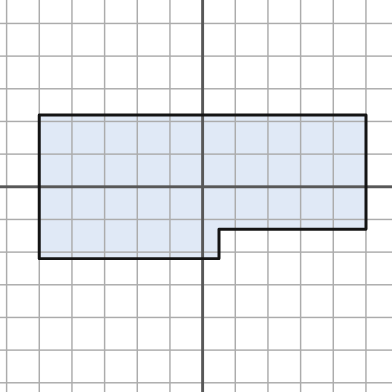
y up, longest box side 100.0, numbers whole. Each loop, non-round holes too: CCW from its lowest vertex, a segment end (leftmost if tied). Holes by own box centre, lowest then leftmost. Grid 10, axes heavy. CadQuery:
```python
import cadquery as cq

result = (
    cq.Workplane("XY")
    .moveTo(-50.0, -22.0)
    .lineTo(5.0, -22.0)
    .lineTo(5.0, -13.0)
    .lineTo(50.0, -13.0)
    .lineTo(50.0, 22.0)
    .lineTo(-50.0, 22.0)
    .close()
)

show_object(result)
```